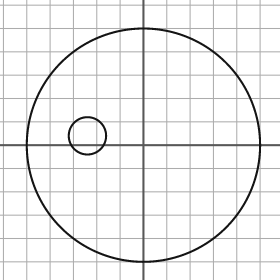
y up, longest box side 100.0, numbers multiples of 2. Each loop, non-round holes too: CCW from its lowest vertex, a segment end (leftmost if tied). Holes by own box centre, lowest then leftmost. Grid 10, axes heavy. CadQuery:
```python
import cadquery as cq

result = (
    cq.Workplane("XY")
    .moveTo(0.0, 0.0)
    .circle(50.0)
    .moveTo(-24.0, 4.0)
    .circle(8.0)
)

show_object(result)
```